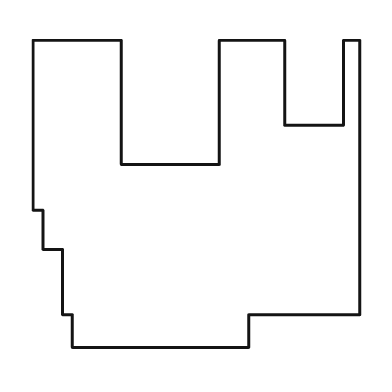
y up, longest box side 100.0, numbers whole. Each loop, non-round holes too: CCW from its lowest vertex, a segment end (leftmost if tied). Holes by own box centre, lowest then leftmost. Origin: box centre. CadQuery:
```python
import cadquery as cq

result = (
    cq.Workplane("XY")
    .moveTo(-38.0, -47.0)
    .lineTo(16.0, -47.0)
    .lineTo(16.0, -37.0)
    .lineTo(50.0, -37.0)
    .lineTo(50.0, 47.0)
    .lineTo(45.0, 47.0)
    .lineTo(45.0, 21.0)
    .lineTo(27.0, 21.0)
    .lineTo(27.0, 47.0)
    .lineTo(7.0, 47.0)
    .lineTo(7.0, 9.0)
    .lineTo(-23.0, 9.0)
    .lineTo(-23.0, 47.0)
    .lineTo(-50.0, 47.0)
    .lineTo(-50.0, -5.0)
    .lineTo(-47.0, -5.0)
    .lineTo(-47.0, -17.0)
    .lineTo(-41.0, -17.0)
    .lineTo(-41.0, -37.0)
    .lineTo(-38.0, -37.0)
    .close()
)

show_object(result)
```